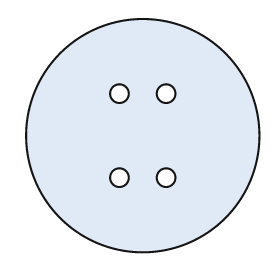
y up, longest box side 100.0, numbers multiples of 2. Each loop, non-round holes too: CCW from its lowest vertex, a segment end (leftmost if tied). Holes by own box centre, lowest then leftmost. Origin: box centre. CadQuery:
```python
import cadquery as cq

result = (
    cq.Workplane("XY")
    .moveTo(0.0, 0.0)
    .circle(50.0)
    .moveTo(-10.0, -18.0)
    .circle(4.0)
    .moveTo(10.0, -18.0)
    .circle(4.0)
    .moveTo(-10.0, 18.0)
    .circle(4.0)
    .moveTo(10.0, 18.0)
    .circle(4.0)
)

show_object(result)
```